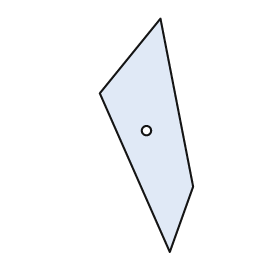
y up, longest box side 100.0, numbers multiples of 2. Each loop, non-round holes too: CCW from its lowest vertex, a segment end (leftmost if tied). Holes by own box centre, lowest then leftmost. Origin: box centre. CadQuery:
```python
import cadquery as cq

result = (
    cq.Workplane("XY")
    .moveTo(10.0, -50.0)
    .lineTo(20.0, -22.0)
    .lineTo(6.0, 50.0)
    .lineTo(-20.0, 18.0)
    .close()
    .moveTo(0.0, 2.0)
    .circle(2.0)
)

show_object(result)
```